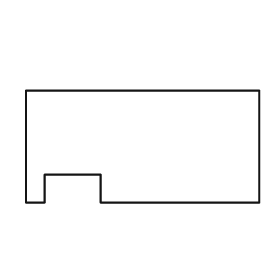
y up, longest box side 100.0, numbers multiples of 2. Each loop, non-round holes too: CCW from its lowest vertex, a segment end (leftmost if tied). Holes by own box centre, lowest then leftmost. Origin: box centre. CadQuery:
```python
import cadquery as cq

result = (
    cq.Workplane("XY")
    .moveTo(-50.0, -24.0)
    .lineTo(-42.0, -24.0)
    .lineTo(-42.0, -12.0)
    .lineTo(-18.0, -12.0)
    .lineTo(-18.0, -24.0)
    .lineTo(50.0, -24.0)
    .lineTo(50.0, 24.0)
    .lineTo(-50.0, 24.0)
    .close()
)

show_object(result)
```